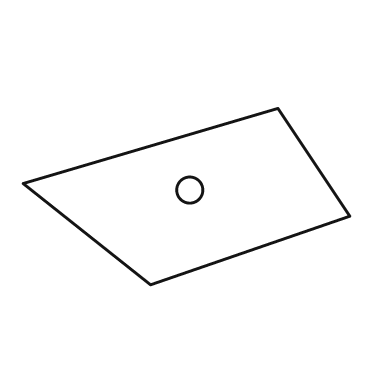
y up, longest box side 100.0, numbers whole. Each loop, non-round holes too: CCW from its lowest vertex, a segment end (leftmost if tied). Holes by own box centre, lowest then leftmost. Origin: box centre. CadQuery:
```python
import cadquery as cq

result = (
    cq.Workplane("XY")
    .moveTo(-11.0, -27.0)
    .lineTo(50.0, -6.0)
    .lineTo(28.0, 27.0)
    .lineTo(-50.0, 4.0)
    .close()
    .moveTo(1.0, 2.0)
    .circle(4.0)
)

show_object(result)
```